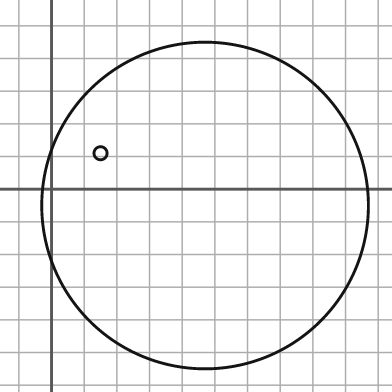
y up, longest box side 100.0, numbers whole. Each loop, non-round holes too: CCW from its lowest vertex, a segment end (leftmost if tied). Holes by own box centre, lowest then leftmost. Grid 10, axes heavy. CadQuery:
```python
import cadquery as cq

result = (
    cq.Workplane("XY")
    .moveTo(47.0, -5.0)
    .circle(50.0)
    .moveTo(15.0, 11.0)
    .circle(2.0)
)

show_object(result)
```